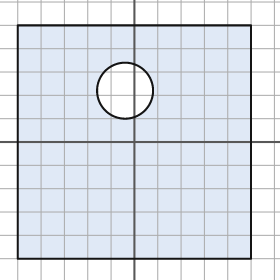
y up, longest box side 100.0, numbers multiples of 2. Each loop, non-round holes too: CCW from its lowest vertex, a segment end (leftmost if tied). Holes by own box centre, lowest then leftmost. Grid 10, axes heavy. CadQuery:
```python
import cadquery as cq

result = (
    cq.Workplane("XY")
    .moveTo(-50.0, -50.0)
    .lineTo(50.0, -50.0)
    .lineTo(50.0, 50.0)
    .lineTo(-50.0, 50.0)
    .close()
    .moveTo(-4.0, 22.0)
    .circle(12.0)
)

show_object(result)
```